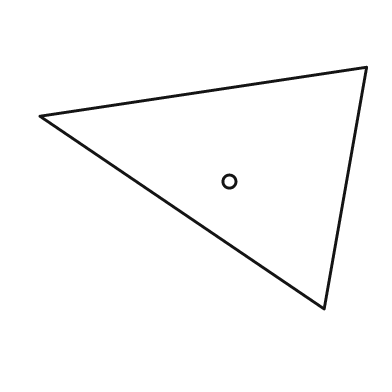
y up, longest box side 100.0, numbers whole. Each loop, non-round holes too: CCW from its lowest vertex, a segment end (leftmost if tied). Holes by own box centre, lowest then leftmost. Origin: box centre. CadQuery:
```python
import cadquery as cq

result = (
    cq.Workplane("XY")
    .moveTo(37.0, -37.0)
    .lineTo(50.0, 37.0)
    .lineTo(-50.0, 22.0)
    .close()
    .moveTo(8.0, 2.0)
    .circle(2.0)
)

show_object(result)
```